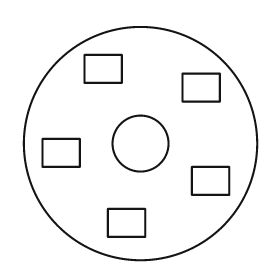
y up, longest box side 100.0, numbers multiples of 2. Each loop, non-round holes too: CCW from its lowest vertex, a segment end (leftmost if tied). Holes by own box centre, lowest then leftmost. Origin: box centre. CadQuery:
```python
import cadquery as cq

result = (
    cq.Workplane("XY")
    .moveTo(0.0, 0.0)
    .circle(50.0)
    .moveTo(-14.0, -40.0)
    .lineTo(2.0, -40.0)
    .lineTo(2.0, -28.0)
    .lineTo(-14.0, -28.0)
    .close()
    .moveTo(22.0, -22.0)
    .lineTo(38.0, -22.0)
    .lineTo(38.0, -10.0)
    .lineTo(22.0, -10.0)
    .close()
    .moveTo(-42.0, -10.0)
    .lineTo(-26.0, -10.0)
    .lineTo(-26.0, 2.0)
    .lineTo(-42.0, 2.0)
    .close()
    .moveTo(0.0, 0.0)
    .circle(12.0)
    .moveTo(18.0, 18.0)
    .lineTo(34.0, 18.0)
    .lineTo(34.0, 30.0)
    .lineTo(18.0, 30.0)
    .close()
    .moveTo(-24.0, 26.0)
    .lineTo(-8.0, 26.0)
    .lineTo(-8.0, 38.0)
    .lineTo(-24.0, 38.0)
    .close()
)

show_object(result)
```